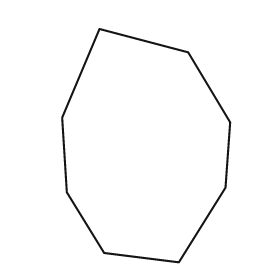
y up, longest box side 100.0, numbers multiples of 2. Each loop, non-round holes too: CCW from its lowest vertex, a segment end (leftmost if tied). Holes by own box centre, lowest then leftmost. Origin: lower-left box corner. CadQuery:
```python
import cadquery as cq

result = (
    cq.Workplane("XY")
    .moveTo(50.0, 0.0)
    .lineTo(70.0, 32.0)
    .lineTo(72.0, 60.0)
    .lineTo(54.0, 90.0)
    .lineTo(16.0, 100.0)
    .lineTo(0.0, 62.0)
    .lineTo(2.0, 30.0)
    .lineTo(18.0, 4.0)
    .close()
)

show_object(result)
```